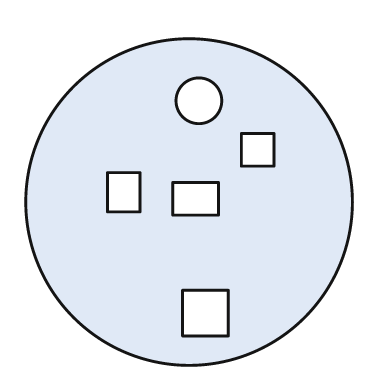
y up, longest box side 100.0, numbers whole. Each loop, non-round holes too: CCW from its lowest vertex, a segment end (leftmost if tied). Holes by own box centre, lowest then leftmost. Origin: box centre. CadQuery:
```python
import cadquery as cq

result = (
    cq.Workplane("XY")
    .moveTo(0.0, 0.0)
    .circle(50.0)
    .moveTo(-2.0, -41.0)
    .lineTo(12.0, -41.0)
    .lineTo(12.0, -27.0)
    .lineTo(-2.0, -27.0)
    .close()
    .moveTo(-5.0, -4.0)
    .lineTo(9.0, -4.0)
    .lineTo(9.0, 6.0)
    .lineTo(-5.0, 6.0)
    .close()
    .moveTo(-25.0, -3.0)
    .lineTo(-15.0, -3.0)
    .lineTo(-15.0, 9.0)
    .lineTo(-25.0, 9.0)
    .close()
    .moveTo(16.0, 11.0)
    .lineTo(26.0, 11.0)
    .lineTo(26.0, 21.0)
    .lineTo(16.0, 21.0)
    .close()
    .moveTo(3.0, 31.0)
    .circle(7.0)
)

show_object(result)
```